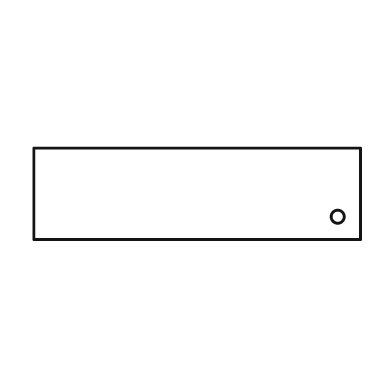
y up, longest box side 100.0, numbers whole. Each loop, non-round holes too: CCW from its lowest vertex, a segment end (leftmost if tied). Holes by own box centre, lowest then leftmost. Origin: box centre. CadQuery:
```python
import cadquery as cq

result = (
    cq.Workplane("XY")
    .moveTo(-50.0, -14.0)
    .lineTo(50.0, -14.0)
    .lineTo(50.0, 14.0)
    .lineTo(-50.0, 14.0)
    .close()
    .moveTo(43.0, -7.0)
    .circle(2.0)
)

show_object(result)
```